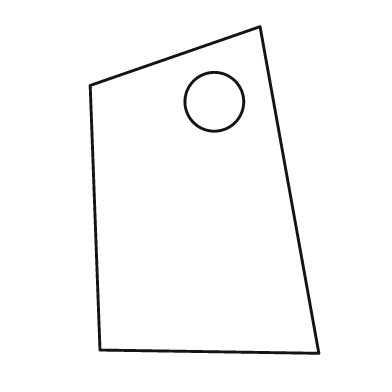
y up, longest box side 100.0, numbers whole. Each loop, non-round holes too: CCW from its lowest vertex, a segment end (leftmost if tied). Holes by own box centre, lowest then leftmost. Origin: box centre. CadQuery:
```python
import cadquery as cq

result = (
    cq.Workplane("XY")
    .moveTo(35.0, -50.0)
    .lineTo(17.0, 50.0)
    .lineTo(-35.0, 32.0)
    .lineTo(-32.0, -49.0)
    .close()
    .moveTo(3.0, 27.0)
    .circle(9.0)
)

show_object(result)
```